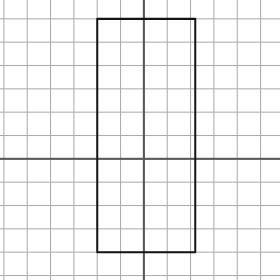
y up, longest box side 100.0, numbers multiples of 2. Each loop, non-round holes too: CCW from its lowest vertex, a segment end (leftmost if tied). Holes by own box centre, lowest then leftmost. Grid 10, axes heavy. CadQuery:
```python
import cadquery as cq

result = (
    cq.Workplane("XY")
    .moveTo(-20.0, -40.0)
    .lineTo(22.0, -40.0)
    .lineTo(22.0, 60.0)
    .lineTo(-20.0, 60.0)
    .close()
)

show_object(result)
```